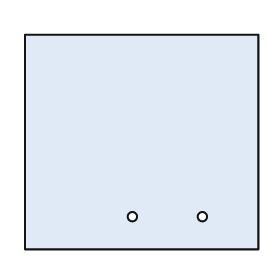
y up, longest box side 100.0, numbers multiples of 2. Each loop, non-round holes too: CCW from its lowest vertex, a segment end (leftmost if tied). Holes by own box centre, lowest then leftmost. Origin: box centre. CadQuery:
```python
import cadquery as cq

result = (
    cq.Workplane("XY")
    .moveTo(-50.0, -46.0)
    .lineTo(50.0, -46.0)
    .lineTo(50.0, 46.0)
    .lineTo(-50.0, 46.0)
    .close()
    .moveTo(-4.0, -32.0)
    .circle(2.0)
    .moveTo(26.0, -32.0)
    .circle(2.0)
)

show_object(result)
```